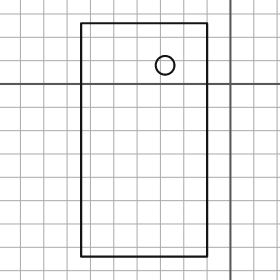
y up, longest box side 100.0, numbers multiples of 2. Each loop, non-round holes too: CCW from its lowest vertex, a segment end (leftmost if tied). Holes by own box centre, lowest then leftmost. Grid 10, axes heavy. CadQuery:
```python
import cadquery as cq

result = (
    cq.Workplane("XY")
    .moveTo(-64.0, -74.0)
    .lineTo(-10.0, -74.0)
    .lineTo(-10.0, 26.0)
    .lineTo(-64.0, 26.0)
    .close()
    .moveTo(-28.0, 8.0)
    .circle(4.0)
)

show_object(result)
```